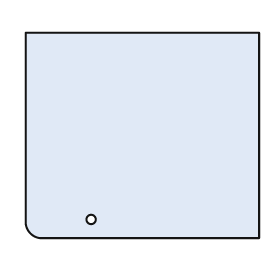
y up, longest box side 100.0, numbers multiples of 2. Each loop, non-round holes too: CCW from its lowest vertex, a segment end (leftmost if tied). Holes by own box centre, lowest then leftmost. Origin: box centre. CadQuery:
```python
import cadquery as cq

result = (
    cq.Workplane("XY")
    .moveTo(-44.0, -44.0)
    .lineTo(50.0, -44.0)
    .lineTo(50.0, 44.0)
    .lineTo(-50.0, 44.0)
    .lineTo(-50.0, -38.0)
    .threePointArc((-48.0, -42.0), (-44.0, -44.0))
    .close()
    .moveTo(-22.0, -36.0)
    .circle(2.0)
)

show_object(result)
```